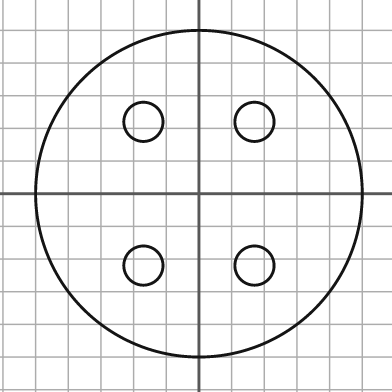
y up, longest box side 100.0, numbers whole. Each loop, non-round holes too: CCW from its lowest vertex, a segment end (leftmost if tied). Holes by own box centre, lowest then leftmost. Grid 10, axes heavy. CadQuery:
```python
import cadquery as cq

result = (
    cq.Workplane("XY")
    .moveTo(0.0, 0.0)
    .circle(50.0)
    .moveTo(-17.0, -22.0)
    .circle(6.0)
    .moveTo(17.0, -22.0)
    .circle(6.0)
    .moveTo(-17.0, 22.0)
    .circle(6.0)
    .moveTo(17.0, 22.0)
    .circle(6.0)
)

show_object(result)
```